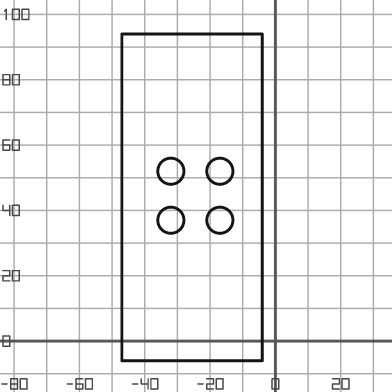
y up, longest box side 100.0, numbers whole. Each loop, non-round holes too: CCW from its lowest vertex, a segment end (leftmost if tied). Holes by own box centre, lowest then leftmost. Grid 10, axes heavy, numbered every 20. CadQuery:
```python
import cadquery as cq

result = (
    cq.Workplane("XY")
    .moveTo(-47.0, -6.0)
    .lineTo(-4.0, -6.0)
    .lineTo(-4.0, 94.0)
    .lineTo(-47.0, 94.0)
    .close()
    .moveTo(-32.0, 37.0)
    .circle(4.0)
    .moveTo(-17.0, 37.0)
    .circle(4.0)
    .moveTo(-32.0, 52.0)
    .circle(4.0)
    .moveTo(-17.0, 52.0)
    .circle(4.0)
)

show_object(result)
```